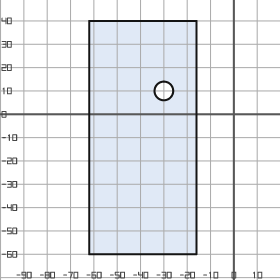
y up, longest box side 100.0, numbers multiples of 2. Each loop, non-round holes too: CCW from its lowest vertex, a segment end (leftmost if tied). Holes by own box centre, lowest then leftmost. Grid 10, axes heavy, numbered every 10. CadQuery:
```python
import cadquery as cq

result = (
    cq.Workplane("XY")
    .moveTo(-62.0, -60.0)
    .lineTo(-16.0, -60.0)
    .lineTo(-16.0, 40.0)
    .lineTo(-62.0, 40.0)
    .close()
    .moveTo(-30.0, 10.0)
    .circle(4.0)
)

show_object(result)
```